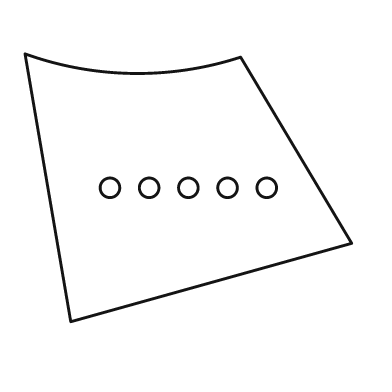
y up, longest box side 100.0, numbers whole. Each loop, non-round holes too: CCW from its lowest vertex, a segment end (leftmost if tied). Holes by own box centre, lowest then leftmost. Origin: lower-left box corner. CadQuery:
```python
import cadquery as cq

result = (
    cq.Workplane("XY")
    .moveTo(14.0, 0.0)
    .lineTo(100.0, 24.0)
    .lineTo(66.0, 81.0)
    .threePointArc((33.0, 76.0), (0.0, 82.0))
    .close()
    .moveTo(26.0, 41.0)
    .circle(3.0)
    .moveTo(38.0, 41.0)
    .circle(3.0)
    .moveTo(50.0, 41.0)
    .circle(3.0)
    .moveTo(62.0, 41.0)
    .circle(3.0)
    .moveTo(74.0, 41.0)
    .circle(3.0)
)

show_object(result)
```